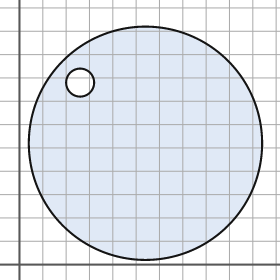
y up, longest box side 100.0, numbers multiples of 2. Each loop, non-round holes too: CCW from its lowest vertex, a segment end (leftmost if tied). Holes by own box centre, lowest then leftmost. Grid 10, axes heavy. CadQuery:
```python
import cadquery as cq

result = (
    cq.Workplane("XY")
    .moveTo(54.0, 52.0)
    .circle(50.0)
    .moveTo(26.0, 78.0)
    .circle(6.0)
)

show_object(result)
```